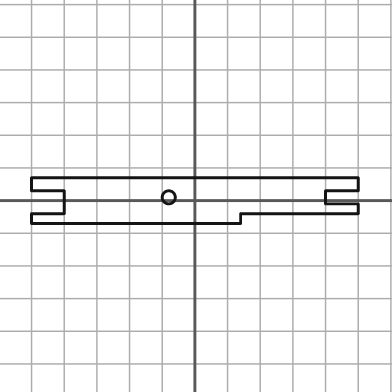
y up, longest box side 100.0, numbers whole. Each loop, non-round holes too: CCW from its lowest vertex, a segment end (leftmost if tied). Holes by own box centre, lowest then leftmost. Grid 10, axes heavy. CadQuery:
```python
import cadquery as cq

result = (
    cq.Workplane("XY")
    .moveTo(-50.0, -7.0)
    .lineTo(14.0, -7.0)
    .lineTo(14.0, -4.0)
    .lineTo(50.0, -4.0)
    .lineTo(50.0, -1.0)
    .lineTo(40.0, -1.0)
    .lineTo(40.0, 3.0)
    .lineTo(50.0, 3.0)
    .lineTo(50.0, 7.0)
    .lineTo(-50.0, 7.0)
    .lineTo(-50.0, 3.0)
    .lineTo(-40.0, 3.0)
    .lineTo(-40.0, -4.0)
    .lineTo(-50.0, -4.0)
    .close()
    .moveTo(-8.0, 1.0)
    .circle(2.0)
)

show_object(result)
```